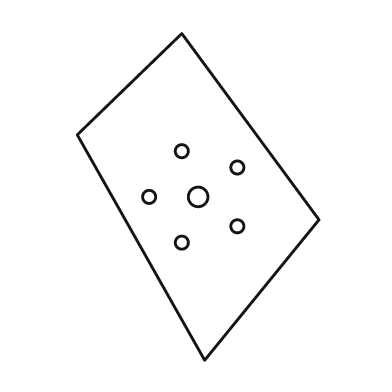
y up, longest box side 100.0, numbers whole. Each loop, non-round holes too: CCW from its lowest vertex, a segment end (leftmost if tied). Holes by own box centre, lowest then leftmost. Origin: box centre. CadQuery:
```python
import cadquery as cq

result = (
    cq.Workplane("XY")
    .moveTo(2.0, -50.0)
    .lineTo(37.0, -7.0)
    .lineTo(-5.0, 50.0)
    .lineTo(-37.0, 19.0)
    .close()
    .moveTo(-5.0, -14.0)
    .circle(2.0)
    .moveTo(12.0, -9.0)
    .circle(2.0)
    .moveTo(-15.0, 0.0)
    .circle(2.0)
    .moveTo(0.0, 0.0)
    .circle(3.0)
    .moveTo(12.0, 9.0)
    .circle(2.0)
    .moveTo(-5.0, 14.0)
    .circle(2.0)
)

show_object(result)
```